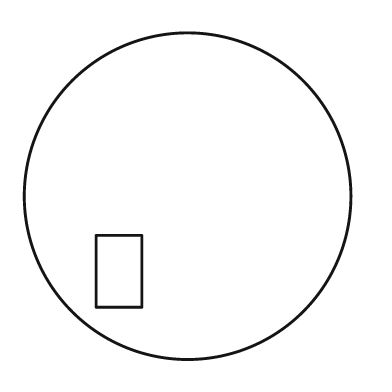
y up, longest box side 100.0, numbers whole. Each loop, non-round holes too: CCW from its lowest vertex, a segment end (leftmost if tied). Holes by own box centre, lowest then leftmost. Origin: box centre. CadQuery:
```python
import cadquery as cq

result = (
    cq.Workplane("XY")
    .moveTo(0.0, 0.0)
    .circle(50.0)
    .moveTo(-28.0, -34.0)
    .lineTo(-14.0, -34.0)
    .lineTo(-14.0, -12.0)
    .lineTo(-28.0, -12.0)
    .close()
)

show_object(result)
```